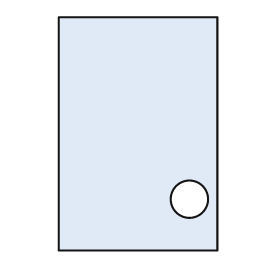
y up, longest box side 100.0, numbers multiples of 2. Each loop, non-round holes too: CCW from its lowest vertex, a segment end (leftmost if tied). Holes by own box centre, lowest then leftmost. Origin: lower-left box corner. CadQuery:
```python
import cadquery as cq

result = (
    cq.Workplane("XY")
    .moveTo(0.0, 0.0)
    .lineTo(68.0, 0.0)
    .lineTo(68.0, 100.0)
    .lineTo(0.0, 100.0)
    .close()
    .moveTo(56.0, 22.0)
    .circle(8.0)
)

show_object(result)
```